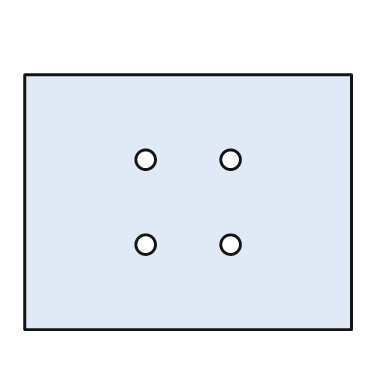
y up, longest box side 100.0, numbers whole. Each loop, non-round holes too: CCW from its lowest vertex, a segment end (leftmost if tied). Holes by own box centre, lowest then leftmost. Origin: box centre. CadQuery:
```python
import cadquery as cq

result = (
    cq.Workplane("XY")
    .moveTo(-50.0, -39.0)
    .lineTo(50.0, -39.0)
    .lineTo(50.0, 39.0)
    .lineTo(-50.0, 39.0)
    .close()
    .moveTo(-13.0, -13.0)
    .circle(3.0)
    .moveTo(13.0, -13.0)
    .circle(3.0)
    .moveTo(-13.0, 13.0)
    .circle(3.0)
    .moveTo(13.0, 13.0)
    .circle(3.0)
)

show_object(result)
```